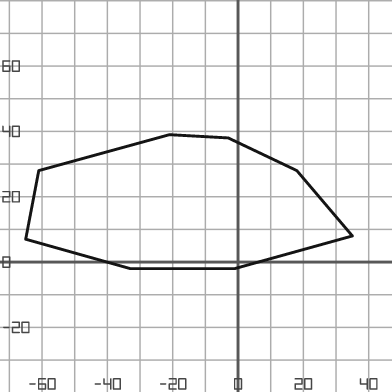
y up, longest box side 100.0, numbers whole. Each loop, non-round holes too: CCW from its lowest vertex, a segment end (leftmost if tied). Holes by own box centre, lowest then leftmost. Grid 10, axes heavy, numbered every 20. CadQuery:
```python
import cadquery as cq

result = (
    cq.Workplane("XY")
    .moveTo(-33.0, -2.0)
    .lineTo(-1.0, -2.0)
    .lineTo(35.0, 8.0)
    .lineTo(18.0, 28.0)
    .lineTo(-3.0, 38.0)
    .lineTo(-21.0, 39.0)
    .lineTo(-61.0, 28.0)
    .lineTo(-65.0, 7.0)
    .close()
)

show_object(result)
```